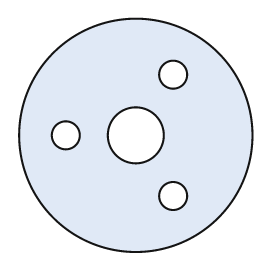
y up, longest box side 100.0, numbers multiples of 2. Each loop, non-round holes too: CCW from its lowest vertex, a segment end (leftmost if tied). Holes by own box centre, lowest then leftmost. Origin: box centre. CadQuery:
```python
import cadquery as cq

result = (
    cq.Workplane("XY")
    .moveTo(0.0, 0.0)
    .circle(50.0)
    .moveTo(16.0, -26.0)
    .circle(6.0)
    .moveTo(-30.0, 0.0)
    .circle(6.0)
    .moveTo(0.0, 0.0)
    .circle(12.0)
    .moveTo(16.0, 26.0)
    .circle(6.0)
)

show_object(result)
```